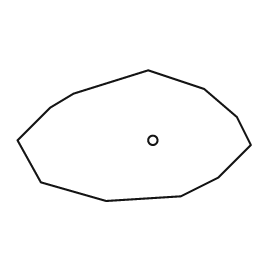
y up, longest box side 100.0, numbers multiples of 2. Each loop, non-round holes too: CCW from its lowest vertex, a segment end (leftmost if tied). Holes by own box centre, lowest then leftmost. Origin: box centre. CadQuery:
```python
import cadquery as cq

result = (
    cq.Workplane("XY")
    .moveTo(-12.0, -28.0)
    .lineTo(20.0, -26.0)
    .lineTo(36.0, -18.0)
    .lineTo(50.0, -4.0)
    .lineTo(44.0, 8.0)
    .lineTo(30.0, 20.0)
    .lineTo(6.0, 28.0)
    .lineTo(-26.0, 18.0)
    .lineTo(-36.0, 12.0)
    .lineTo(-50.0, -2.0)
    .lineTo(-40.0, -20.0)
    .close()
    .moveTo(8.0, -2.0)
    .circle(2.0)
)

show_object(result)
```